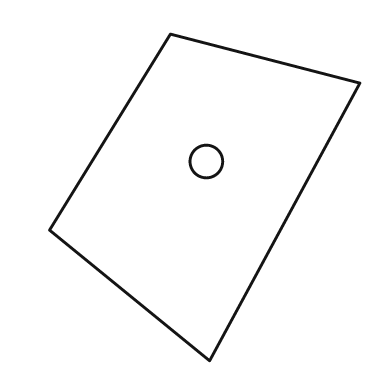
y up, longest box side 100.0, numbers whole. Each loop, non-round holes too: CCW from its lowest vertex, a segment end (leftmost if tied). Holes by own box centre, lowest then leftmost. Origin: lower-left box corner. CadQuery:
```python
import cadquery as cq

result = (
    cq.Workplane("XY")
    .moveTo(49.0, 0.0)
    .lineTo(95.0, 85.0)
    .lineTo(37.0, 100.0)
    .lineTo(0.0, 40.0)
    .close()
    .moveTo(48.0, 61.0)
    .circle(5.0)
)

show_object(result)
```